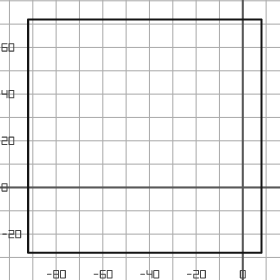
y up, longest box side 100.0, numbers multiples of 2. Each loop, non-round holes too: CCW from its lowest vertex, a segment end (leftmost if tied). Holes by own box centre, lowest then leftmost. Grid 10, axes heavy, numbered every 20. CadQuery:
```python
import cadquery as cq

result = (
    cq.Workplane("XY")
    .moveTo(-92.0, -28.0)
    .lineTo(8.0, -28.0)
    .lineTo(8.0, 72.0)
    .lineTo(-92.0, 72.0)
    .close()
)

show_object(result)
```